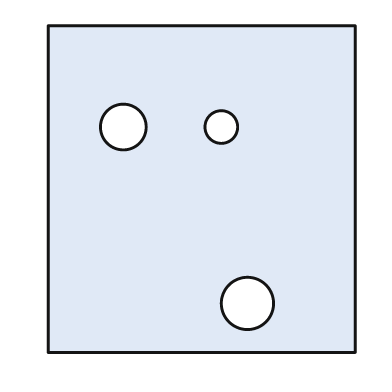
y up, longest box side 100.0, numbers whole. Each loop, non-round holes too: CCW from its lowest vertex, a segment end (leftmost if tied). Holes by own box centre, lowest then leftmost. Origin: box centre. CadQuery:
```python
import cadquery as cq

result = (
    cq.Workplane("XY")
    .moveTo(-47.0, -50.0)
    .lineTo(47.0, -50.0)
    .lineTo(47.0, 50.0)
    .lineTo(-47.0, 50.0)
    .close()
    .moveTo(14.0, -35.0)
    .circle(8.0)
    .moveTo(-24.0, 19.0)
    .circle(7.0)
    .moveTo(6.0, 19.0)
    .circle(5.0)
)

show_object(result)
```